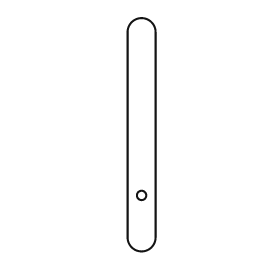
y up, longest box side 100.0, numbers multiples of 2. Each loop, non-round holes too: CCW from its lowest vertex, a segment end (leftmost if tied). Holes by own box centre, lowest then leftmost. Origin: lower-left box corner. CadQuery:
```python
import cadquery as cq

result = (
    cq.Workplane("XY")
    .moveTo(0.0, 6.0)
    .threePointArc((6.0, 0.0), (12.0, 6.0))
    .lineTo(12.0, 94.0)
    .threePointArc((6.0, 100.0), (0.0, 94.0))
    .close()
    .moveTo(6.0, 24.0)
    .circle(2.0)
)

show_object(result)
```